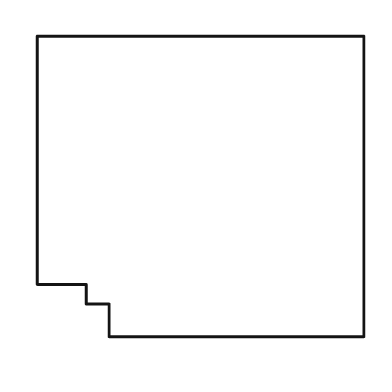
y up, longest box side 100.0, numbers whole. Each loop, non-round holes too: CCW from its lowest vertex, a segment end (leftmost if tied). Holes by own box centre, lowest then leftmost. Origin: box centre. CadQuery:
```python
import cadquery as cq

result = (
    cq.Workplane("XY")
    .moveTo(-28.0, -46.0)
    .lineTo(50.0, -46.0)
    .lineTo(50.0, 46.0)
    .lineTo(-50.0, 46.0)
    .lineTo(-50.0, -30.0)
    .lineTo(-35.0, -30.0)
    .lineTo(-35.0, -36.0)
    .lineTo(-28.0, -36.0)
    .close()
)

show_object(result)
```